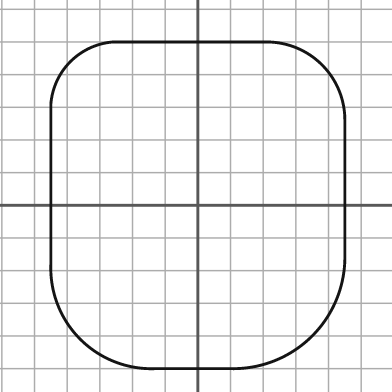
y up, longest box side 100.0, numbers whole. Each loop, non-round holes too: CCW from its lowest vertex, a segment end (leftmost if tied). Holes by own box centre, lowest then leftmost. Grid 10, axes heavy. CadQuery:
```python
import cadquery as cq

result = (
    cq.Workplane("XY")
    .moveTo(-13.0, -50.0)
    .lineTo(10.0, -50.0)
    .threePointArc((35.0, -40.0), (45.0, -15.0))
    .lineTo(45.0, 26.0)
    .threePointArc((38.0, 43.0), (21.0, 50.0))
    .lineTo(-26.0, 50.0)
    .threePointArc((-39.0, 44.0), (-45.0, 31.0))
    .lineTo(-45.0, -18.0)
    .threePointArc((-36.0, -41.0), (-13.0, -50.0))
    .close()
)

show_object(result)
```